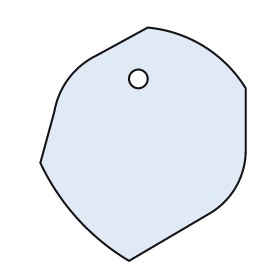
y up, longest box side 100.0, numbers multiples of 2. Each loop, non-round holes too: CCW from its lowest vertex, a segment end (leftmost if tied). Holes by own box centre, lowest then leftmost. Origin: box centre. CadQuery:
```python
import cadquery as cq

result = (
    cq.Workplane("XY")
    .moveTo(-6.0, -50.0)
    .lineTo(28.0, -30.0)
    .threePointArc((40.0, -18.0), (44.0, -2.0))
    .lineTo(44.0, 24.0)
    .threePointArc((26.0, 42.0), (2.0, 50.0))
    .lineTo(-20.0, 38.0)
    .threePointArc((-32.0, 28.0), (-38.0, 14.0))
    .lineTo(-44.0, -8.0)
    .threePointArc((-28.0, -32.0), (-6.0, -50.0))
    .close()
    .moveTo(-2.0, 28.0)
    .circle(4.0)
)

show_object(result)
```